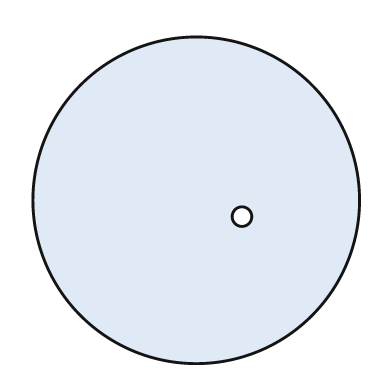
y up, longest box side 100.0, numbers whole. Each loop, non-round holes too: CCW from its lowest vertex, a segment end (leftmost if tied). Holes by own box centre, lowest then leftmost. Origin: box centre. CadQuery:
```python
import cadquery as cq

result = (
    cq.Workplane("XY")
    .moveTo(0.0, 0.0)
    .circle(50.0)
    .moveTo(14.0, -5.0)
    .circle(3.0)
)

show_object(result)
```